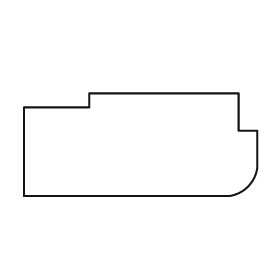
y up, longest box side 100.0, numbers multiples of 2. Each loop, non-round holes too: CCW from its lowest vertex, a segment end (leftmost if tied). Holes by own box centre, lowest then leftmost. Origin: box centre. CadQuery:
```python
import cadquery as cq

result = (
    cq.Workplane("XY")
    .moveTo(-50.0, -22.0)
    .lineTo(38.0, -22.0)
    .threePointArc((46.0, -18.0), (50.0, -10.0))
    .lineTo(50.0, 6.0)
    .lineTo(42.0, 6.0)
    .lineTo(42.0, 22.0)
    .lineTo(-22.0, 22.0)
    .lineTo(-22.0, 16.0)
    .lineTo(-50.0, 16.0)
    .close()
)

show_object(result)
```